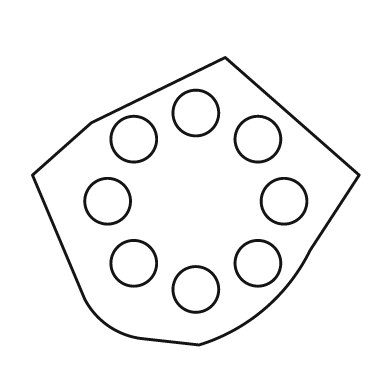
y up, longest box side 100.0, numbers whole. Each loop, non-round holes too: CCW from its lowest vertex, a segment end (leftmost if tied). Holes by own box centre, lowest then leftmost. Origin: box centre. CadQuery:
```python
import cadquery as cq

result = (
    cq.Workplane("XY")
    .moveTo(1.0, -44.0)
    .threePointArc((21.0, -33.0), (35.0, -15.0))
    .lineTo(50.0, 8.0)
    .lineTo(9.0, 44.0)
    .lineTo(-32.0, 24.0)
    .lineTo(-50.0, 8.0)
    .lineTo(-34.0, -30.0)
    .threePointArc((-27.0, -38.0), (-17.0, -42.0))
    .close()
    .moveTo(0.0, -27.0)
    .circle(7.0)
    .moveTo(-19.0, -19.0)
    .circle(7.0)
    .moveTo(19.0, -19.0)
    .circle(7.0)
    .moveTo(-27.0, 0.0)
    .circle(7.0)
    .moveTo(27.0, 0.0)
    .circle(7.0)
    .moveTo(-19.0, 19.0)
    .circle(7.0)
    .moveTo(19.0, 19.0)
    .circle(7.0)
    .moveTo(0.0, 27.0)
    .circle(7.0)
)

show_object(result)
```